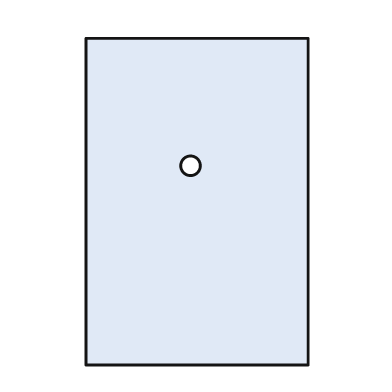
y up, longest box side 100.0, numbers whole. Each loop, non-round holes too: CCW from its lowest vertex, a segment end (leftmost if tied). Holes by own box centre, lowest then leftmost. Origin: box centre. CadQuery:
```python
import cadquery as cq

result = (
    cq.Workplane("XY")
    .moveTo(-34.0, -50.0)
    .lineTo(34.0, -50.0)
    .lineTo(34.0, 50.0)
    .lineTo(-34.0, 50.0)
    .close()
    .moveTo(-2.0, 11.0)
    .circle(3.0)
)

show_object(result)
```